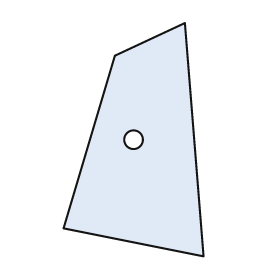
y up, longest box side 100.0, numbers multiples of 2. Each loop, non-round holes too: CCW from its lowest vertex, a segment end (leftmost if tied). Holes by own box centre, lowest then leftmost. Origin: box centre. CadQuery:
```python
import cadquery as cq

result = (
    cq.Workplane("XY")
    .moveTo(30.0, -50.0)
    .lineTo(22.0, 50.0)
    .lineTo(-8.0, 36.0)
    .lineTo(-30.0, -38.0)
    .close()
    .moveTo(0.0, 0.0)
    .circle(4.0)
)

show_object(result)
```